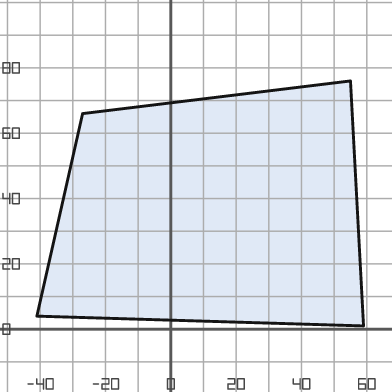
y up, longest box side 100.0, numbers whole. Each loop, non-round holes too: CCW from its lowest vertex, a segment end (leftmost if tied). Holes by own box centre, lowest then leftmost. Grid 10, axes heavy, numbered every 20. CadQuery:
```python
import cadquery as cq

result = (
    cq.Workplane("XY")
    .moveTo(59.0, 1.0)
    .lineTo(55.0, 76.0)
    .lineTo(-27.0, 66.0)
    .lineTo(-41.0, 4.0)
    .close()
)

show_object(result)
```